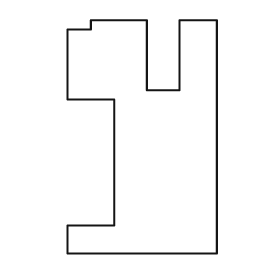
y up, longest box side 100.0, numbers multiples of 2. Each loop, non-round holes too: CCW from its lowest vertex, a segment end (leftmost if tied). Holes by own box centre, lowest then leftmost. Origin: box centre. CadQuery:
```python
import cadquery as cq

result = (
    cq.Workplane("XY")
    .moveTo(-32.0, -50.0)
    .lineTo(32.0, -50.0)
    .lineTo(32.0, 50.0)
    .lineTo(16.0, 50.0)
    .lineTo(16.0, 20.0)
    .lineTo(2.0, 20.0)
    .lineTo(2.0, 50.0)
    .lineTo(-22.0, 50.0)
    .lineTo(-22.0, 46.0)
    .lineTo(-32.0, 46.0)
    .lineTo(-32.0, 16.0)
    .lineTo(-12.0, 16.0)
    .lineTo(-12.0, -38.0)
    .lineTo(-32.0, -38.0)
    .close()
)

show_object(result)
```